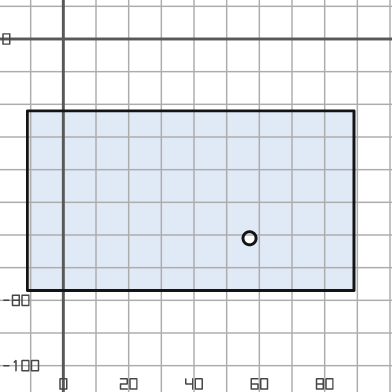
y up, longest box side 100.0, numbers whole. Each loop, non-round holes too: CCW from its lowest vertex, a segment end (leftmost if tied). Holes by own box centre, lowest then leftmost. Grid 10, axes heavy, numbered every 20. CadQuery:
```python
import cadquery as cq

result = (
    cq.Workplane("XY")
    .moveTo(-11.0, -77.0)
    .lineTo(89.0, -77.0)
    .lineTo(89.0, -22.0)
    .lineTo(-11.0, -22.0)
    .close()
    .moveTo(57.0, -61.0)
    .circle(2.0)
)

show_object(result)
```